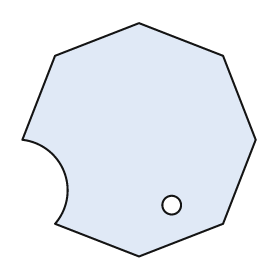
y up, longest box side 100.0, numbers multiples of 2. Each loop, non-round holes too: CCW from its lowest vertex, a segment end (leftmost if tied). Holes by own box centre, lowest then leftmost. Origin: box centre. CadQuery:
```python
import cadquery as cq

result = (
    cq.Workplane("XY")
    .moveTo(0.0, -50.0)
    .lineTo(36.0, -36.0)
    .lineTo(50.0, 0.0)
    .lineTo(36.0, 36.0)
    .lineTo(0.0, 50.0)
    .lineTo(-36.0, 36.0)
    .lineTo(-50.0, 0.0)
    .threePointArc((-32.0, -14.0), (-36.0, -36.0))
    .close()
    .moveTo(14.0, -28.0)
    .circle(4.0)
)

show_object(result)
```